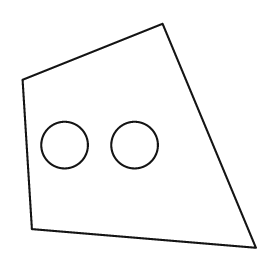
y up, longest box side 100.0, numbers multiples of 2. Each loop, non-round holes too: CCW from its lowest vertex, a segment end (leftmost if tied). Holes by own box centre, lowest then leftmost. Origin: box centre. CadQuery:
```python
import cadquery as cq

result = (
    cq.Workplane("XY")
    .moveTo(50.0, -48.0)
    .lineTo(10.0, 48.0)
    .lineTo(-50.0, 24.0)
    .lineTo(-46.0, -40.0)
    .close()
    .moveTo(-32.0, -4.0)
    .circle(10.0)
    .moveTo(-2.0, -4.0)
    .circle(10.0)
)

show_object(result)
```